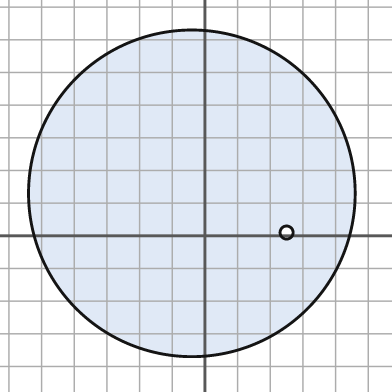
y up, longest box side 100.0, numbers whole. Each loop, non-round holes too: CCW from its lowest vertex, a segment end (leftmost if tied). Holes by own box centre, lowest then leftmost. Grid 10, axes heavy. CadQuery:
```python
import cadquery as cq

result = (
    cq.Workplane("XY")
    .moveTo(-4.0, 13.0)
    .circle(50.0)
    .moveTo(25.0, 1.0)
    .circle(2.0)
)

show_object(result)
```